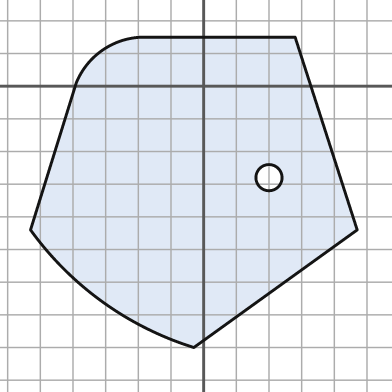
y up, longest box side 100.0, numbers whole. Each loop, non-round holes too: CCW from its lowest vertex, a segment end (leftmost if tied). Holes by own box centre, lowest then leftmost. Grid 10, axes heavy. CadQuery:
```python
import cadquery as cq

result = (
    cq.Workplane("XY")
    .moveTo(-3.0, -80.0)
    .lineTo(47.0, -44.0)
    .lineTo(28.0, 15.0)
    .lineTo(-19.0, 15.0)
    .threePointArc((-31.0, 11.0), (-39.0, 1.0))
    .lineTo(-53.0, -44.0)
    .threePointArc((-31.0, -66.0), (-3.0, -80.0))
    .close()
    .moveTo(20.0, -28.0)
    .circle(4.0)
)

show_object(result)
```